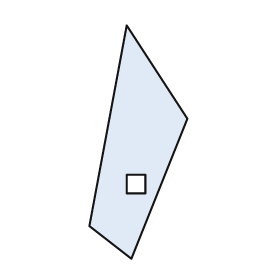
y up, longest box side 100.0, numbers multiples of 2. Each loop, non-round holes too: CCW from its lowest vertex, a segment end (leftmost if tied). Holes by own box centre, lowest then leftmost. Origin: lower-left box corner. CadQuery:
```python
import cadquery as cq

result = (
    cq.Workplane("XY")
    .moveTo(18.0, 0.0)
    .lineTo(42.0, 60.0)
    .lineTo(16.0, 100.0)
    .lineTo(0.0, 14.0)
    .close()
    .moveTo(16.0, 28.0)
    .lineTo(24.0, 28.0)
    .lineTo(24.0, 36.0)
    .lineTo(16.0, 36.0)
    .close()
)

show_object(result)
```